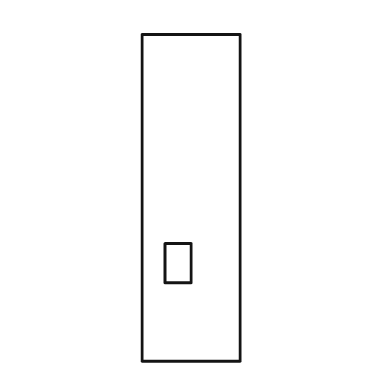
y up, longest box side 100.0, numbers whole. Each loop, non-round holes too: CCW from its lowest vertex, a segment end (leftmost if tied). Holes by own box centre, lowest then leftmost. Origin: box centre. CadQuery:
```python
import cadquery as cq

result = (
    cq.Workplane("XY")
    .moveTo(-15.0, -50.0)
    .lineTo(15.0, -50.0)
    .lineTo(15.0, 50.0)
    .lineTo(-15.0, 50.0)
    .close()
    .moveTo(-8.0, -26.0)
    .lineTo(0.0, -26.0)
    .lineTo(0.0, -14.0)
    .lineTo(-8.0, -14.0)
    .close()
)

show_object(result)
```